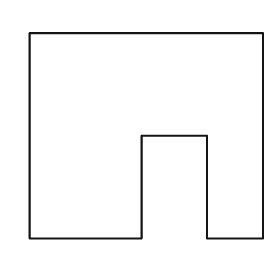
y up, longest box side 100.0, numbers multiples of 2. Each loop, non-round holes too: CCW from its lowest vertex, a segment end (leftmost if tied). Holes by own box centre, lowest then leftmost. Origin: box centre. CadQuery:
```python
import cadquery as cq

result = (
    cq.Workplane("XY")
    .moveTo(-50.0, -44.0)
    .lineTo(-2.0, -44.0)
    .lineTo(-2.0, 0.0)
    .lineTo(26.0, 0.0)
    .lineTo(26.0, -44.0)
    .lineTo(50.0, -44.0)
    .lineTo(50.0, 44.0)
    .lineTo(-50.0, 44.0)
    .close()
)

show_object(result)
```